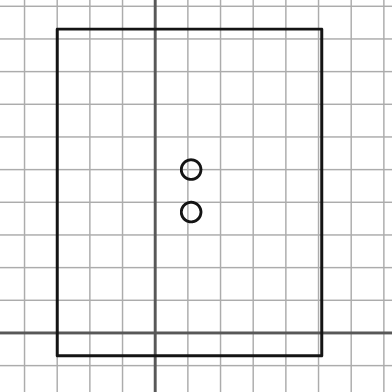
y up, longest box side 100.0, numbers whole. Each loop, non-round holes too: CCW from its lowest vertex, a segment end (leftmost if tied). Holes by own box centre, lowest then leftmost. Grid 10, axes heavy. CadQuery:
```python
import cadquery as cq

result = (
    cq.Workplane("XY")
    .moveTo(-30.0, -7.0)
    .lineTo(51.0, -7.0)
    .lineTo(51.0, 93.0)
    .lineTo(-30.0, 93.0)
    .close()
    .moveTo(11.0, 37.0)
    .circle(3.0)
    .moveTo(11.0, 50.0)
    .circle(3.0)
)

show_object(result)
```